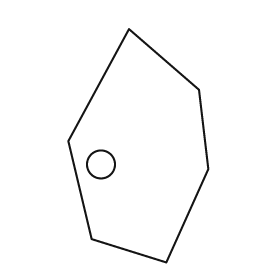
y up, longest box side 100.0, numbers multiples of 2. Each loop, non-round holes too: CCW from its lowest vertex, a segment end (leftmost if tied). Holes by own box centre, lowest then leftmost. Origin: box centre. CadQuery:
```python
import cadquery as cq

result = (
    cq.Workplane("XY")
    .moveTo(12.0, -50.0)
    .lineTo(30.0, -10.0)
    .lineTo(26.0, 24.0)
    .lineTo(-4.0, 50.0)
    .lineTo(-30.0, 2.0)
    .lineTo(-20.0, -40.0)
    .close()
    .moveTo(-16.0, -8.0)
    .circle(6.0)
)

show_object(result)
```